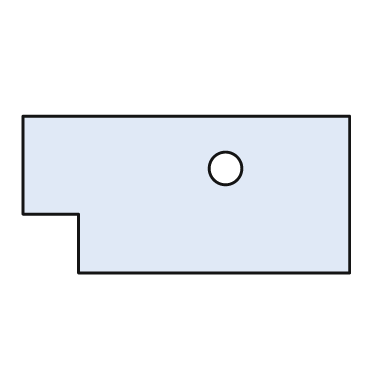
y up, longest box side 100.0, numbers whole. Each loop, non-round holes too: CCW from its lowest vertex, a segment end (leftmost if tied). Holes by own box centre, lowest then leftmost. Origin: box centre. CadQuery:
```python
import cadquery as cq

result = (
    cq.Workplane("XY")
    .moveTo(-33.0, -24.0)
    .lineTo(50.0, -24.0)
    .lineTo(50.0, 24.0)
    .lineTo(-50.0, 24.0)
    .lineTo(-50.0, -6.0)
    .lineTo(-33.0, -6.0)
    .close()
    .moveTo(12.0, 8.0)
    .circle(5.0)
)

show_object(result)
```